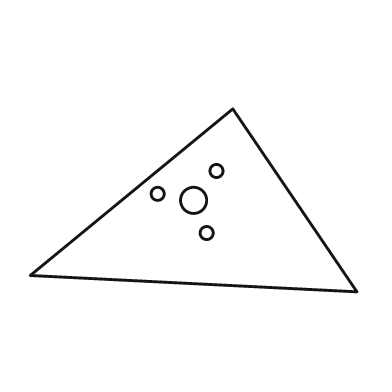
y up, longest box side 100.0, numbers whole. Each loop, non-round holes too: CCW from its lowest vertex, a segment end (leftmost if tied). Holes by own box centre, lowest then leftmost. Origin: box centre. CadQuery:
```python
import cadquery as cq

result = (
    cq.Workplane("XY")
    .moveTo(50.0, -28.0)
    .lineTo(12.0, 28.0)
    .lineTo(-50.0, -23.0)
    .close()
    .moveTo(4.0, -10.0)
    .circle(2.0)
    .moveTo(0.0, 0.0)
    .circle(4.0)
    .moveTo(-11.0, 2.0)
    .circle(2.0)
    .moveTo(7.0, 9.0)
    .circle(2.0)
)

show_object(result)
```